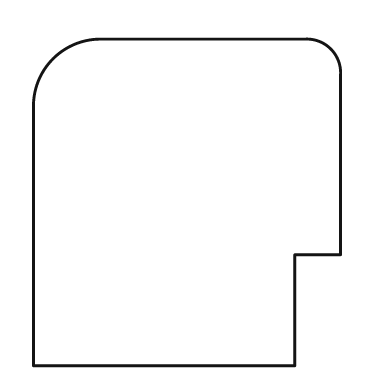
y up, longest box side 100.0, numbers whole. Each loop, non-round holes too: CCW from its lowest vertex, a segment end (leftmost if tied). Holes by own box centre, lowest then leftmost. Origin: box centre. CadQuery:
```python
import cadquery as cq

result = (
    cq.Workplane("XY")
    .moveTo(-47.0, -50.0)
    .lineTo(33.0, -50.0)
    .lineTo(33.0, -16.0)
    .lineTo(47.0, -16.0)
    .lineTo(47.0, 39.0)
    .threePointArc((44.0, 47.0), (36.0, 50.0))
    .lineTo(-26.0, 50.0)
    .threePointArc((-41.0, 44.0), (-47.0, 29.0))
    .close()
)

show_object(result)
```